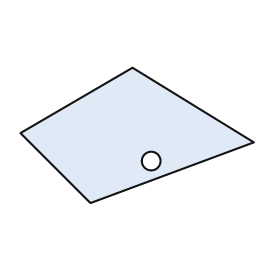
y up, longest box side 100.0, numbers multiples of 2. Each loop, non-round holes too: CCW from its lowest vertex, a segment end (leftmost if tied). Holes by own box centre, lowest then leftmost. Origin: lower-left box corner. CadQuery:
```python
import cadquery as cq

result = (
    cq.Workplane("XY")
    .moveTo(30.0, 0.0)
    .lineTo(100.0, 26.0)
    .lineTo(48.0, 58.0)
    .lineTo(0.0, 30.0)
    .close()
    .moveTo(56.0, 18.0)
    .circle(4.0)
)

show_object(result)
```